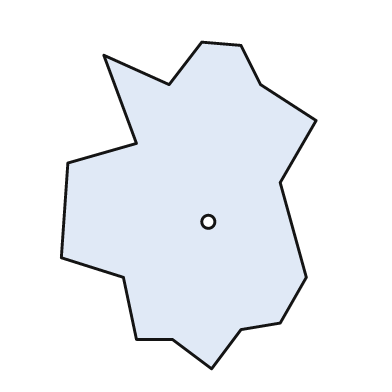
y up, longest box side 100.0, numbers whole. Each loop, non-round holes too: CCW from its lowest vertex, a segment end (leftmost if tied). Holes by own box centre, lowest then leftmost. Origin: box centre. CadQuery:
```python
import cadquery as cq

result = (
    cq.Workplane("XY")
    .moveTo(7.0, -50.0)
    .lineTo(16.0, -38.0)
    .lineTo(28.0, -36.0)
    .lineTo(36.0, -22.0)
    .lineTo(28.0, 7.0)
    .lineTo(39.0, 26.0)
    .lineTo(22.0, 37.0)
    .lineTo(16.0, 49.0)
    .lineTo(4.0, 50.0)
    .lineTo(-6.0, 37.0)
    .lineTo(-26.0, 46.0)
    .lineTo(-16.0, 19.0)
    .lineTo(-37.0, 13.0)
    .lineTo(-39.0, -16.0)
    .lineTo(-20.0, -22.0)
    .lineTo(-16.0, -41.0)
    .lineTo(-5.0, -41.0)
    .close()
    .moveTo(6.0, -5.0)
    .circle(2.0)
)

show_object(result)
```